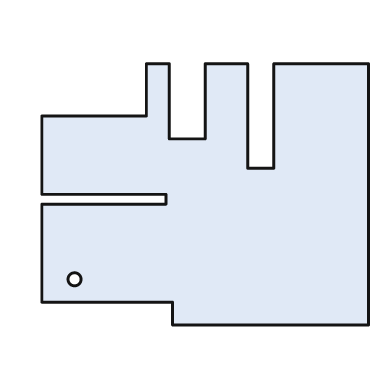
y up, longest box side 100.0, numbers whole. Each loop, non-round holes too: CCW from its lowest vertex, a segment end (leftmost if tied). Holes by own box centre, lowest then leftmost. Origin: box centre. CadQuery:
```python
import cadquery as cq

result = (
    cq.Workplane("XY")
    .moveTo(-10.0, -40.0)
    .lineTo(50.0, -40.0)
    .lineTo(50.0, 40.0)
    .lineTo(21.0, 40.0)
    .lineTo(21.0, 8.0)
    .lineTo(13.0, 8.0)
    .lineTo(13.0, 40.0)
    .lineTo(0.0, 40.0)
    .lineTo(0.0, 17.0)
    .lineTo(-11.0, 17.0)
    .lineTo(-11.0, 40.0)
    .lineTo(-18.0, 40.0)
    .lineTo(-18.0, 24.0)
    .lineTo(-50.0, 24.0)
    .lineTo(-50.0, 0.0)
    .lineTo(-12.0, 0.0)
    .lineTo(-12.0, -3.0)
    .lineTo(-50.0, -3.0)
    .lineTo(-50.0, -33.0)
    .lineTo(-10.0, -33.0)
    .close()
    .moveTo(-40.0, -26.0)
    .circle(2.0)
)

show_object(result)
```